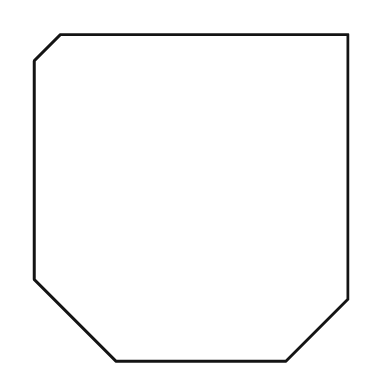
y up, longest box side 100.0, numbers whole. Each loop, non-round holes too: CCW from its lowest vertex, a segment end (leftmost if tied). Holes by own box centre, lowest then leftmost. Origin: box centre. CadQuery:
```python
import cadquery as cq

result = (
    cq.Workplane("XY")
    .moveTo(-23.0, -50.0)
    .lineTo(29.0, -50.0)
    .lineTo(48.0, -31.0)
    .lineTo(48.0, 50.0)
    .lineTo(-40.0, 50.0)
    .lineTo(-48.0, 42.0)
    .lineTo(-48.0, -25.0)
    .close()
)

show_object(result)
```